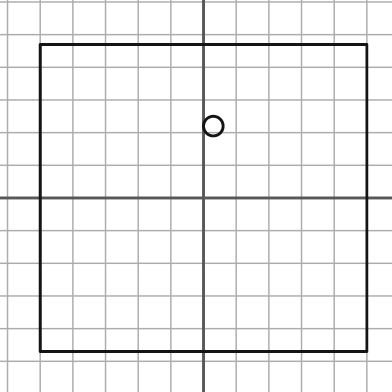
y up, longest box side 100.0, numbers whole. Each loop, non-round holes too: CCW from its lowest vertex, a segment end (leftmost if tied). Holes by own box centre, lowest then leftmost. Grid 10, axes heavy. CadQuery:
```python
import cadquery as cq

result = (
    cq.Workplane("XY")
    .moveTo(-50.0, -47.0)
    .lineTo(50.0, -47.0)
    .lineTo(50.0, 47.0)
    .lineTo(-50.0, 47.0)
    .close()
    .moveTo(3.0, 22.0)
    .circle(3.0)
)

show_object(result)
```